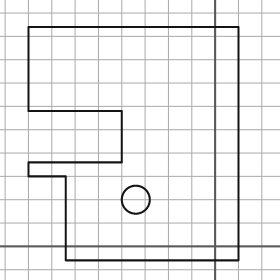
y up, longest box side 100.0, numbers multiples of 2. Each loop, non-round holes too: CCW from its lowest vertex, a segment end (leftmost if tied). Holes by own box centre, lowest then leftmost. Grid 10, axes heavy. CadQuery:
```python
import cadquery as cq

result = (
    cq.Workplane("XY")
    .moveTo(-64.0, -6.0)
    .lineTo(10.0, -6.0)
    .lineTo(10.0, 94.0)
    .lineTo(-80.0, 94.0)
    .lineTo(-80.0, 58.0)
    .lineTo(-40.0, 58.0)
    .lineTo(-40.0, 36.0)
    .lineTo(-80.0, 36.0)
    .lineTo(-80.0, 30.0)
    .lineTo(-64.0, 30.0)
    .close()
    .moveTo(-34.0, 20.0)
    .circle(6.0)
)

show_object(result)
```